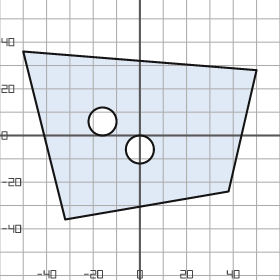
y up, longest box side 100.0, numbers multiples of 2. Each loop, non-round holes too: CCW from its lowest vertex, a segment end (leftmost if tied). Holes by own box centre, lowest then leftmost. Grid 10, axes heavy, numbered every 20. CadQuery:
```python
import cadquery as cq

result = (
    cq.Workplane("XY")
    .moveTo(-32.0, -36.0)
    .lineTo(38.0, -24.0)
    .lineTo(50.0, 28.0)
    .lineTo(-50.0, 36.0)
    .close()
    .moveTo(0.0, -6.0)
    .circle(6.0)
    .moveTo(-16.0, 6.0)
    .circle(6.0)
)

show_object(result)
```